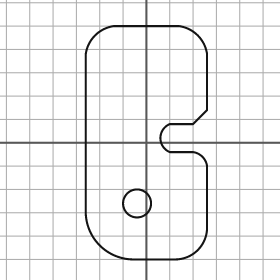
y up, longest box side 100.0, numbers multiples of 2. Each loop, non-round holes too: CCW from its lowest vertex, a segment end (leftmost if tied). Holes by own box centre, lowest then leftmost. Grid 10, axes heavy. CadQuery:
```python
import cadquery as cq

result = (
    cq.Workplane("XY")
    .moveTo(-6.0, -50.0)
    .lineTo(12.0, -50.0)
    .threePointArc((22.0, -46.0), (26.0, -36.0))
    .lineTo(26.0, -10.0)
    .threePointArc((24.0, -6.0), (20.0, -4.0))
    .lineTo(10.0, -4.0)
    .threePointArc((6.0, 2.0), (10.0, 8.0))
    .lineTo(20.0, 8.0)
    .lineTo(26.0, 14.0)
    .lineTo(26.0, 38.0)
    .threePointArc((22.0, 46.0), (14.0, 50.0))
    .lineTo(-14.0, 50.0)
    .threePointArc((-22.0, 46.0), (-26.0, 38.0))
    .lineTo(-26.0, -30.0)
    .threePointArc((-20.0, -44.0), (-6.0, -50.0))
    .close()
    .moveTo(-4.0, -26.0)
    .circle(6.0)
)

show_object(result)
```